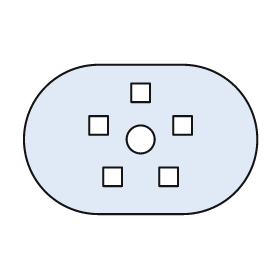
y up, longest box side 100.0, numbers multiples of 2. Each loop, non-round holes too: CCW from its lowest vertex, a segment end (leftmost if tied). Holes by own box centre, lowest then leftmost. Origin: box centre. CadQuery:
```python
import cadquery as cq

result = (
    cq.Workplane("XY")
    .moveTo(-18.0, -32.0)
    .lineTo(18.0, -32.0)
    .threePointArc((50.0, 0.0), (18.0, 32.0))
    .lineTo(-18.0, 32.0)
    .threePointArc((-50.0, 0.0), (-18.0, -32.0))
    .close()
    .moveTo(-16.0, -20.0)
    .lineTo(-8.0, -20.0)
    .lineTo(-8.0, -12.0)
    .lineTo(-16.0, -12.0)
    .close()
    .moveTo(8.0, -20.0)
    .lineTo(16.0, -20.0)
    .lineTo(16.0, -12.0)
    .lineTo(8.0, -12.0)
    .close()
    .moveTo(0.0, 0.0)
    .circle(6.0)
    .moveTo(-22.0, 2.0)
    .lineTo(-14.0, 2.0)
    .lineTo(-14.0, 10.0)
    .lineTo(-22.0, 10.0)
    .close()
    .moveTo(14.0, 2.0)
    .lineTo(22.0, 2.0)
    .lineTo(22.0, 10.0)
    .lineTo(14.0, 10.0)
    .close()
    .moveTo(-4.0, 16.0)
    .lineTo(4.0, 16.0)
    .lineTo(4.0, 24.0)
    .lineTo(-4.0, 24.0)
    .close()
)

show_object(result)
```